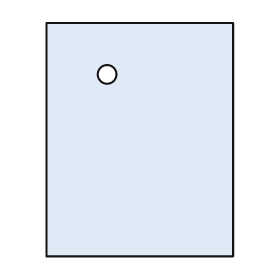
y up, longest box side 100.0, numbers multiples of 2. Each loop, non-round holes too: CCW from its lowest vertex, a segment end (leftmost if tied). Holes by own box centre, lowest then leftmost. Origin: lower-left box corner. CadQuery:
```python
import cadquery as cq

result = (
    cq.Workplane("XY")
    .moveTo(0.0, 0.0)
    .lineTo(80.0, 0.0)
    .lineTo(80.0, 100.0)
    .lineTo(0.0, 100.0)
    .close()
    .moveTo(26.0, 78.0)
    .circle(4.0)
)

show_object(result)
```